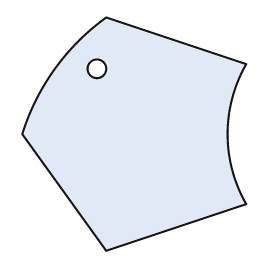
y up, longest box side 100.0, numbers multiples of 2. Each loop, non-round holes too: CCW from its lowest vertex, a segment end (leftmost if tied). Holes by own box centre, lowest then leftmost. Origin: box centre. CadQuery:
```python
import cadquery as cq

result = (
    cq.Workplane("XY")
    .moveTo(-12.0, -50.0)
    .lineTo(48.0, -30.0)
    .threePointArc((40.0, 0.0), (48.0, 30.0))
    .lineTo(-12.0, 50.0)
    .threePointArc((-34.0, 28.0), (-48.0, 0.0))
    .close()
    .moveTo(-16.0, 28.0)
    .circle(4.0)
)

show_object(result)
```